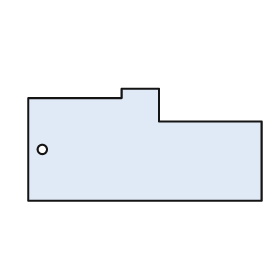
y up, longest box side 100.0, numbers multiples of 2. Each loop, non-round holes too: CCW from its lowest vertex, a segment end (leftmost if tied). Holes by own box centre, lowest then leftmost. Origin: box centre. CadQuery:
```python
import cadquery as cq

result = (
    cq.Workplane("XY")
    .moveTo(-50.0, -24.0)
    .lineTo(50.0, -24.0)
    .lineTo(50.0, 10.0)
    .lineTo(6.0, 10.0)
    .lineTo(6.0, 24.0)
    .lineTo(-10.0, 24.0)
    .lineTo(-10.0, 20.0)
    .lineTo(-50.0, 20.0)
    .close()
    .moveTo(-44.0, -2.0)
    .circle(2.0)
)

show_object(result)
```